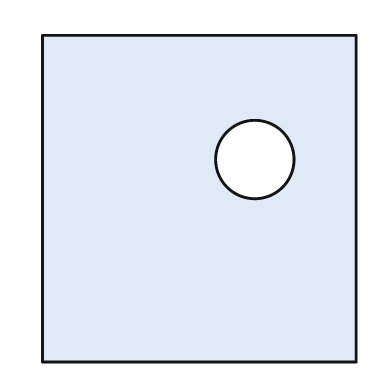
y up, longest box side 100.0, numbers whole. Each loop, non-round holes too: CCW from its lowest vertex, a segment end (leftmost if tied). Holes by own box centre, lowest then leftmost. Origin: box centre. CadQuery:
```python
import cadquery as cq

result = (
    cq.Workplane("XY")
    .moveTo(-48.0, -50.0)
    .lineTo(48.0, -50.0)
    .lineTo(48.0, 50.0)
    .lineTo(-48.0, 50.0)
    .close()
    .moveTo(17.0, 12.0)
    .circle(12.0)
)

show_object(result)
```